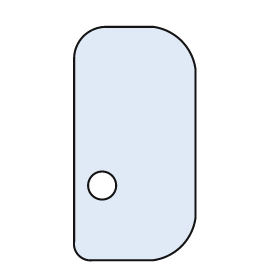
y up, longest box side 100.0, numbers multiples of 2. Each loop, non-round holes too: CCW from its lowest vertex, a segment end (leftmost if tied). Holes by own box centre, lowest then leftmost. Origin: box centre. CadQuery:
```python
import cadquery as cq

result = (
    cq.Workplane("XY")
    .moveTo(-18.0, -50.0)
    .lineTo(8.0, -50.0)
    .threePointArc((20.0, -44.0), (26.0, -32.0))
    .lineTo(26.0, 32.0)
    .threePointArc((20.0, 44.0), (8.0, 50.0))
    .lineTo(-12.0, 50.0)
    .threePointArc((-22.0, 46.0), (-26.0, 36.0))
    .lineTo(-26.0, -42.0)
    .threePointArc((-24.0, -48.0), (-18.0, -50.0))
    .close()
    .moveTo(-14.0, -18.0)
    .circle(6.0)
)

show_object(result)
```